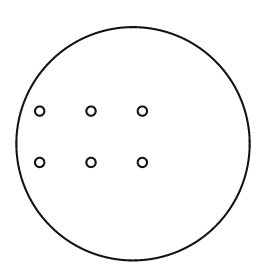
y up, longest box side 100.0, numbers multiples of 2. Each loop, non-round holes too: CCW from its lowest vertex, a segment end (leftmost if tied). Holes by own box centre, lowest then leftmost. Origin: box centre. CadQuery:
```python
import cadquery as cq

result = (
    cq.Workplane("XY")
    .moveTo(0.0, 0.0)
    .circle(50.0)
    .moveTo(-40.0, -8.0)
    .circle(2.0)
    .moveTo(-18.0, -8.0)
    .circle(2.0)
    .moveTo(4.0, -8.0)
    .circle(2.0)
    .moveTo(-40.0, 14.0)
    .circle(2.0)
    .moveTo(-18.0, 14.0)
    .circle(2.0)
    .moveTo(4.0, 14.0)
    .circle(2.0)
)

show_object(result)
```